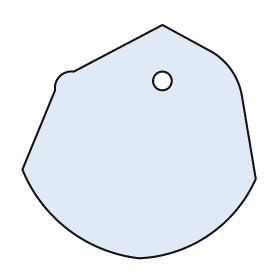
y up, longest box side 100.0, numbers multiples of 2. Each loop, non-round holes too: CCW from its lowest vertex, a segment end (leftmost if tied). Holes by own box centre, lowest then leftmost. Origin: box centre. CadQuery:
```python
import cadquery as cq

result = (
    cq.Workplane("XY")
    .moveTo(0.0, -50.0)
    .threePointArc((30.0, -40.0), (50.0, -16.0))
    .lineTo(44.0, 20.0)
    .threePointArc((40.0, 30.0), (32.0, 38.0))
    .lineTo(10.0, 50.0)
    .lineTo(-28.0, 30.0)
    .threePointArc((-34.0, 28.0), (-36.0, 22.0))
    .lineTo(-50.0, -12.0)
    .threePointArc((-30.0, -38.0), (0.0, -50.0))
    .close()
    .moveTo(10.0, 26.0)
    .circle(4.0)
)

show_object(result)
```